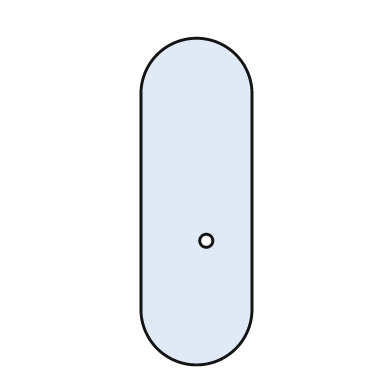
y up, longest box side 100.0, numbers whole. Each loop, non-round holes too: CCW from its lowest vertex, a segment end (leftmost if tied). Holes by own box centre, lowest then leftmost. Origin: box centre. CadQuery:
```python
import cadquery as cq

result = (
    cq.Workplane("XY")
    .moveTo(-17.0, -33.0)
    .threePointArc((0.0, -50.0), (17.0, -33.0))
    .lineTo(17.0, 33.0)
    .threePointArc((0.0, 50.0), (-17.0, 33.0))
    .close()
    .moveTo(3.0, -12.0)
    .circle(2.0)
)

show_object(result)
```